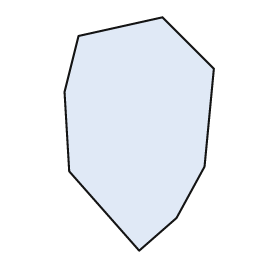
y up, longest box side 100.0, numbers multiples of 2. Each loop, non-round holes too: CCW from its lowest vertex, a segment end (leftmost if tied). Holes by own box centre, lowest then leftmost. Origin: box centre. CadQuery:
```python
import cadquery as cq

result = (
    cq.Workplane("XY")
    .moveTo(0.0, -50.0)
    .lineTo(16.0, -36.0)
    .lineTo(28.0, -14.0)
    .lineTo(32.0, 28.0)
    .lineTo(10.0, 50.0)
    .lineTo(-26.0, 42.0)
    .lineTo(-32.0, 18.0)
    .lineTo(-30.0, -16.0)
    .close()
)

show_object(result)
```